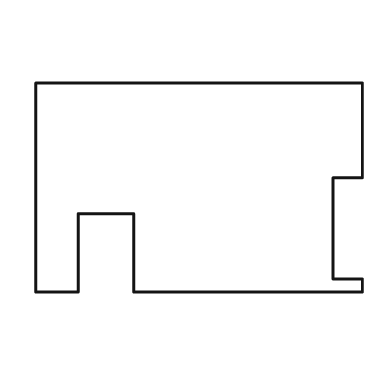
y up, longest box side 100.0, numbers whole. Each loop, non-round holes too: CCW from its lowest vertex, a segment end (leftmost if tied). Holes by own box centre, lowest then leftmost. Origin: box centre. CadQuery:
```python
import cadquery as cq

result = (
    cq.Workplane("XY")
    .moveTo(-50.0, -32.0)
    .lineTo(-37.0, -32.0)
    .lineTo(-37.0, -8.0)
    .lineTo(-20.0, -8.0)
    .lineTo(-20.0, -32.0)
    .lineTo(50.0, -32.0)
    .lineTo(50.0, -28.0)
    .lineTo(41.0, -28.0)
    .lineTo(41.0, 3.0)
    .lineTo(50.0, 3.0)
    .lineTo(50.0, 32.0)
    .lineTo(-50.0, 32.0)
    .close()
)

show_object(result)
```